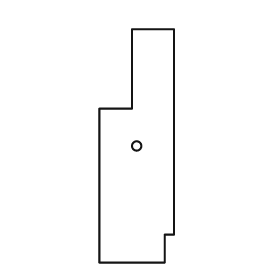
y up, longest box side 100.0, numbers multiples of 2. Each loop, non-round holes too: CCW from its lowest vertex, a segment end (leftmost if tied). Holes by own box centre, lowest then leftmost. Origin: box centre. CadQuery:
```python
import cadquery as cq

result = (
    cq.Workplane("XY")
    .moveTo(-16.0, -50.0)
    .lineTo(12.0, -50.0)
    .lineTo(12.0, -38.0)
    .lineTo(16.0, -38.0)
    .lineTo(16.0, 50.0)
    .lineTo(-2.0, 50.0)
    .lineTo(-2.0, 16.0)
    .lineTo(-16.0, 16.0)
    .close()
    .moveTo(0.0, 0.0)
    .circle(2.0)
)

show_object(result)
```